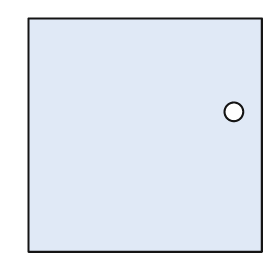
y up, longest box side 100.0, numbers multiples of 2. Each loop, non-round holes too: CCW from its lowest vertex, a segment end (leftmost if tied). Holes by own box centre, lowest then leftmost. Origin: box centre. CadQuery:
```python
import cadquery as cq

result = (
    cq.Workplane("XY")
    .moveTo(-50.0, -50.0)
    .lineTo(50.0, -50.0)
    .lineTo(50.0, 50.0)
    .lineTo(-50.0, 50.0)
    .close()
    .moveTo(38.0, 10.0)
    .circle(4.0)
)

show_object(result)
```